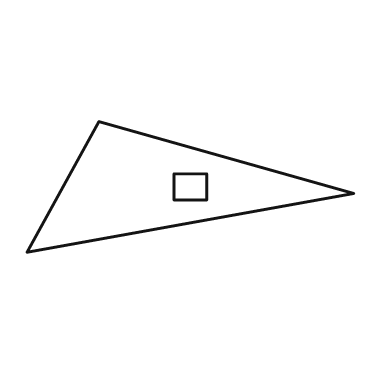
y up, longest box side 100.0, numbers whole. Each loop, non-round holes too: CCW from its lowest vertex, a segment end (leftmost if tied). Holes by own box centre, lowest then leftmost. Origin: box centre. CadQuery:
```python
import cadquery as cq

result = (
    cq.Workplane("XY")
    .moveTo(-50.0, -20.0)
    .lineTo(50.0, -2.0)
    .lineTo(-28.0, 20.0)
    .close()
    .moveTo(-5.0, -4.0)
    .lineTo(5.0, -4.0)
    .lineTo(5.0, 4.0)
    .lineTo(-5.0, 4.0)
    .close()
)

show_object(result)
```